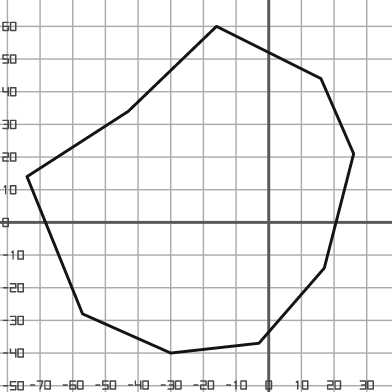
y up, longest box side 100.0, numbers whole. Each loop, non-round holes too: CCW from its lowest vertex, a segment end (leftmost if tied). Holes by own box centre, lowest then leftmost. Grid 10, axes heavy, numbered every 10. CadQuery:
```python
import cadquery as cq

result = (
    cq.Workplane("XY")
    .moveTo(-30.0, -40.0)
    .lineTo(-3.0, -37.0)
    .lineTo(17.0, -14.0)
    .lineTo(26.0, 21.0)
    .lineTo(16.0, 44.0)
    .lineTo(-16.0, 60.0)
    .lineTo(-43.0, 34.0)
    .lineTo(-74.0, 14.0)
    .lineTo(-57.0, -28.0)
    .close()
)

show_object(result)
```